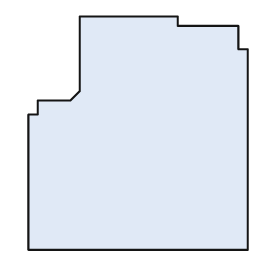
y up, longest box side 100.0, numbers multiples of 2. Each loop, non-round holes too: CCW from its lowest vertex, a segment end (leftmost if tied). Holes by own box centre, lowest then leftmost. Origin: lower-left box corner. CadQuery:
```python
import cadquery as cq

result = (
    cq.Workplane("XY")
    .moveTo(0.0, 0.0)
    .lineTo(94.0, 0.0)
    .lineTo(94.0, 86.0)
    .lineTo(90.0, 86.0)
    .lineTo(90.0, 96.0)
    .lineTo(64.0, 96.0)
    .lineTo(64.0, 100.0)
    .lineTo(22.0, 100.0)
    .lineTo(22.0, 68.0)
    .lineTo(18.0, 64.0)
    .lineTo(4.0, 64.0)
    .lineTo(4.0, 58.0)
    .lineTo(0.0, 58.0)
    .close()
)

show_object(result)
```